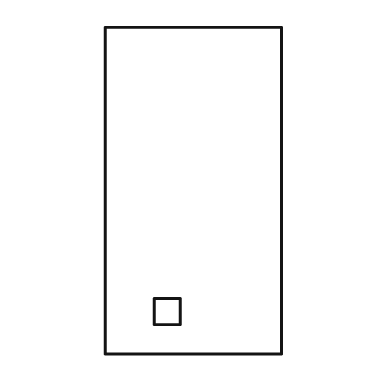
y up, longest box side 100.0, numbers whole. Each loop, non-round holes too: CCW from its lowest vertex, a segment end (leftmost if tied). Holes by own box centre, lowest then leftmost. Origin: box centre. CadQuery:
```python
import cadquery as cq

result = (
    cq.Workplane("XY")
    .moveTo(-27.0, -50.0)
    .lineTo(27.0, -50.0)
    .lineTo(27.0, 50.0)
    .lineTo(-27.0, 50.0)
    .close()
    .moveTo(-12.0, -41.0)
    .lineTo(-4.0, -41.0)
    .lineTo(-4.0, -33.0)
    .lineTo(-12.0, -33.0)
    .close()
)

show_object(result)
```